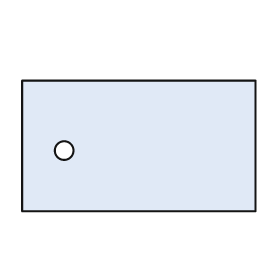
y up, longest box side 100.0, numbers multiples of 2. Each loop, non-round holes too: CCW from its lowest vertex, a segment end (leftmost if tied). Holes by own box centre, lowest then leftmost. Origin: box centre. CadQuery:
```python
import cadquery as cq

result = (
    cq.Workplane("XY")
    .moveTo(-50.0, -28.0)
    .lineTo(50.0, -28.0)
    .lineTo(50.0, 28.0)
    .lineTo(-50.0, 28.0)
    .close()
    .moveTo(-32.0, -2.0)
    .circle(4.0)
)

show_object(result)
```